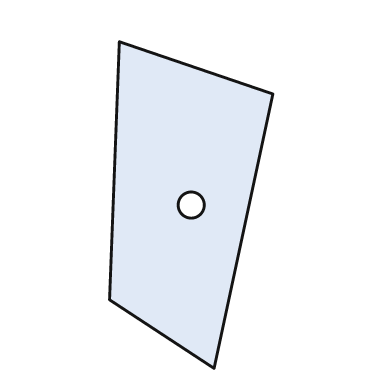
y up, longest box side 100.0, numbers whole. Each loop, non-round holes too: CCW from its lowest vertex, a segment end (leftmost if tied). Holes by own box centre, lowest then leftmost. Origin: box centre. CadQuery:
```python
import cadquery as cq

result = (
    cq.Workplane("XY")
    .moveTo(7.0, -50.0)
    .lineTo(25.0, 34.0)
    .lineTo(-22.0, 50.0)
    .lineTo(-25.0, -29.0)
    .close()
    .moveTo(0.0, 0.0)
    .circle(4.0)
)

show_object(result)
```